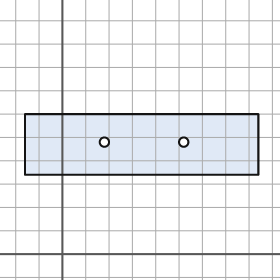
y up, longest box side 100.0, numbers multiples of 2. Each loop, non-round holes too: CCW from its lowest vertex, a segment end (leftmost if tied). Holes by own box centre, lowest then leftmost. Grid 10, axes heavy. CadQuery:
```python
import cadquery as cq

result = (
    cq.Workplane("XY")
    .moveTo(-16.0, 34.0)
    .lineTo(84.0, 34.0)
    .lineTo(84.0, 60.0)
    .lineTo(-16.0, 60.0)
    .close()
    .moveTo(18.0, 48.0)
    .circle(2.0)
    .moveTo(52.0, 48.0)
    .circle(2.0)
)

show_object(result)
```